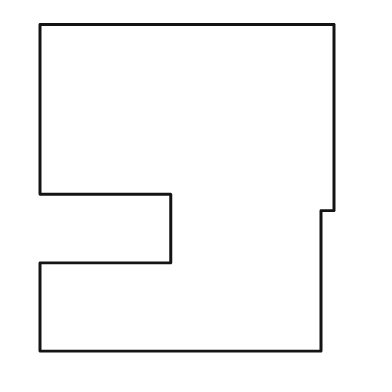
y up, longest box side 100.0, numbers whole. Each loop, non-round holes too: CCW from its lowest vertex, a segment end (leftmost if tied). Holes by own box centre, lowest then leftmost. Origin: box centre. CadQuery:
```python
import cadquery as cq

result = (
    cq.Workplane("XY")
    .moveTo(-45.0, -50.0)
    .lineTo(41.0, -50.0)
    .lineTo(41.0, -7.0)
    .lineTo(45.0, -7.0)
    .lineTo(45.0, 50.0)
    .lineTo(-45.0, 50.0)
    .lineTo(-45.0, -2.0)
    .lineTo(-5.0, -2.0)
    .lineTo(-5.0, -23.0)
    .lineTo(-45.0, -23.0)
    .close()
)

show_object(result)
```